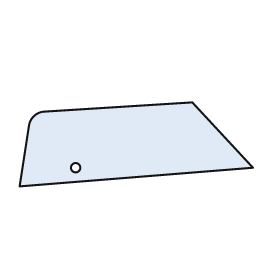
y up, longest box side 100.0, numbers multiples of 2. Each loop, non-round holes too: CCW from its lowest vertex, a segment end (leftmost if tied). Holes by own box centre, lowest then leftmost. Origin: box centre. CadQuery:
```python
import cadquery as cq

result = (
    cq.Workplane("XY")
    .moveTo(-50.0, -18.0)
    .lineTo(50.0, -10.0)
    .lineTo(24.0, 18.0)
    .lineTo(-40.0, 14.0)
    .threePointArc((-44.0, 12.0), (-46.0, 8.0))
    .close()
    .moveTo(-26.0, -10.0)
    .circle(2.0)
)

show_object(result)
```